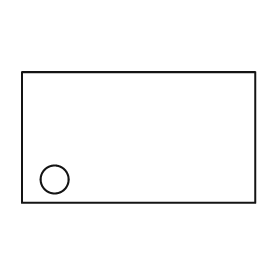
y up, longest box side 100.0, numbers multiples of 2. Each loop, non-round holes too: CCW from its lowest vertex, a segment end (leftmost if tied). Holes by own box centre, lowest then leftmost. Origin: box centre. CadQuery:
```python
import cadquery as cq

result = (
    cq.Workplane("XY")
    .moveTo(-50.0, -28.0)
    .lineTo(50.0, -28.0)
    .lineTo(50.0, 28.0)
    .lineTo(-50.0, 28.0)
    .close()
    .moveTo(-36.0, -18.0)
    .circle(6.0)
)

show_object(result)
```